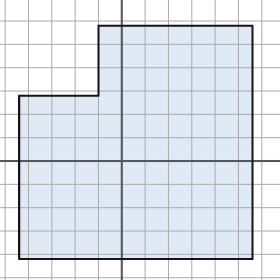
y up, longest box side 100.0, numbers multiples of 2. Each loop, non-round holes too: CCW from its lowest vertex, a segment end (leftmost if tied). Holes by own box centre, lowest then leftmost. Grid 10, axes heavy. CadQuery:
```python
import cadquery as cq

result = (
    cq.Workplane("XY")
    .moveTo(-44.0, -42.0)
    .lineTo(56.0, -42.0)
    .lineTo(56.0, 58.0)
    .lineTo(-10.0, 58.0)
    .lineTo(-10.0, 28.0)
    .lineTo(-44.0, 28.0)
    .close()
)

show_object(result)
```